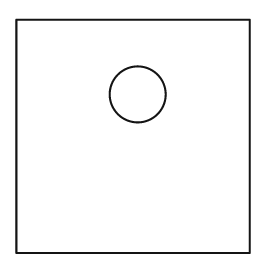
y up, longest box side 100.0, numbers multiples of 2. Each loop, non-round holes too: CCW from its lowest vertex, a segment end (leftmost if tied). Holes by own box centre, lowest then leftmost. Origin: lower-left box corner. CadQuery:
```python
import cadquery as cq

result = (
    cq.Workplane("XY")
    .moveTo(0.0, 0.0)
    .lineTo(100.0, 0.0)
    .lineTo(100.0, 100.0)
    .lineTo(0.0, 100.0)
    .close()
    .moveTo(52.0, 68.0)
    .circle(12.0)
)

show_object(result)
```